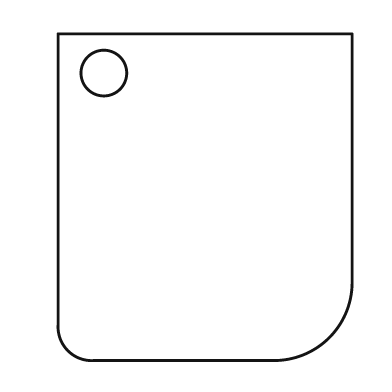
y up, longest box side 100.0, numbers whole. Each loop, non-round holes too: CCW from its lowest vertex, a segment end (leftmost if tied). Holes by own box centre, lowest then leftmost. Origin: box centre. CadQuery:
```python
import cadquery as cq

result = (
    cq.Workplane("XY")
    .moveTo(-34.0, -50.0)
    .lineTo(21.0, -50.0)
    .threePointArc((38.0, -43.0), (45.0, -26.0))
    .lineTo(45.0, 50.0)
    .lineTo(-45.0, 50.0)
    .lineTo(-45.0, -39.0)
    .threePointArc((-42.0, -47.0), (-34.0, -50.0))
    .close()
    .moveTo(-31.0, 38.0)
    .circle(7.0)
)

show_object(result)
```